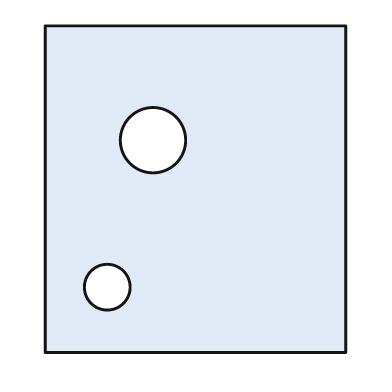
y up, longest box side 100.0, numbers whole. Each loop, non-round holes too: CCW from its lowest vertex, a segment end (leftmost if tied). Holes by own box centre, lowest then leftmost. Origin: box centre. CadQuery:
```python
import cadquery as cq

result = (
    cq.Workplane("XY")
    .moveTo(-46.0, -50.0)
    .lineTo(46.0, -50.0)
    .lineTo(46.0, 50.0)
    .lineTo(-46.0, 50.0)
    .close()
    .moveTo(-27.0, -30.0)
    .circle(7.0)
    .moveTo(-13.0, 15.0)
    .circle(10.0)
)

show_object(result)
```